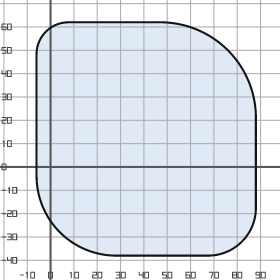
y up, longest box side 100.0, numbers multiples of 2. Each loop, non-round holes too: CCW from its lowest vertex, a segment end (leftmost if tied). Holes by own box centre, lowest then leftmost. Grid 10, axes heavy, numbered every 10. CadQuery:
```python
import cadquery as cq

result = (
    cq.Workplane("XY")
    .moveTo(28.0, -38.0)
    .lineTo(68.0, -38.0)
    .threePointArc((82.0, -32.0), (88.0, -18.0))
    .lineTo(88.0, 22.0)
    .threePointArc((76.0, 50.0), (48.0, 62.0))
    .lineTo(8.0, 62.0)
    .threePointArc((-2.0, 58.0), (-6.0, 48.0))
    .lineTo(-6.0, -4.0)
    .threePointArc((4.0, -28.0), (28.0, -38.0))
    .close()
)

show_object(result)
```